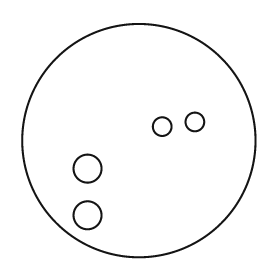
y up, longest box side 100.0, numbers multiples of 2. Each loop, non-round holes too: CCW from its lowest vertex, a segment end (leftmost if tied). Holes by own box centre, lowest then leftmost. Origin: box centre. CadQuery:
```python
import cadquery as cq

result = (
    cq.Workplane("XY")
    .moveTo(0.0, 0.0)
    .circle(50.0)
    .moveTo(-22.0, -32.0)
    .circle(6.0)
    .moveTo(-22.0, -12.0)
    .circle(6.0)
    .moveTo(10.0, 6.0)
    .circle(4.0)
    .moveTo(24.0, 8.0)
    .circle(4.0)
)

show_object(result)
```